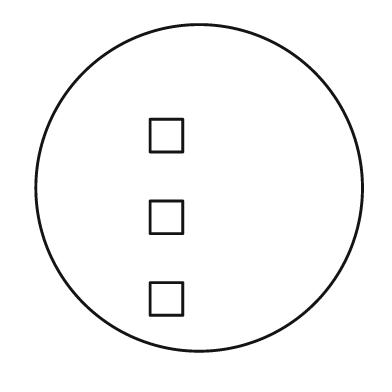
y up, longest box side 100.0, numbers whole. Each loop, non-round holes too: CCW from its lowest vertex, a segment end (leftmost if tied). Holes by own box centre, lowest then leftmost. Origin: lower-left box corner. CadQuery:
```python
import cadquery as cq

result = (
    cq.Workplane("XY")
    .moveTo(50.0, 50.0)
    .circle(50.0)
    .moveTo(35.0, 11.0)
    .lineTo(45.0, 11.0)
    .lineTo(45.0, 21.0)
    .lineTo(35.0, 21.0)
    .close()
    .moveTo(35.0, 36.0)
    .lineTo(45.0, 36.0)
    .lineTo(45.0, 46.0)
    .lineTo(35.0, 46.0)
    .close()
    .moveTo(35.0, 61.0)
    .lineTo(45.0, 61.0)
    .lineTo(45.0, 71.0)
    .lineTo(35.0, 71.0)
    .close()
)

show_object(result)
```